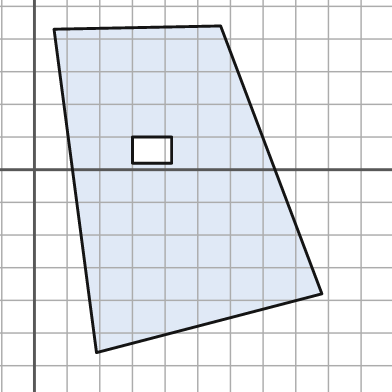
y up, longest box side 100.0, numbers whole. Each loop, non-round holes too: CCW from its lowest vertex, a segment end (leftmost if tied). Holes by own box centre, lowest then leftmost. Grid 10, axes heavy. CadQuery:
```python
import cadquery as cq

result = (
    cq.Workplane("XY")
    .moveTo(19.0, -56.0)
    .lineTo(88.0, -38.0)
    .lineTo(57.0, 44.0)
    .lineTo(6.0, 43.0)
    .close()
    .moveTo(30.0, 2.0)
    .lineTo(42.0, 2.0)
    .lineTo(42.0, 10.0)
    .lineTo(30.0, 10.0)
    .close()
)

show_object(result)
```